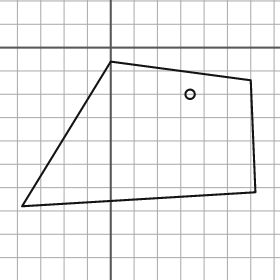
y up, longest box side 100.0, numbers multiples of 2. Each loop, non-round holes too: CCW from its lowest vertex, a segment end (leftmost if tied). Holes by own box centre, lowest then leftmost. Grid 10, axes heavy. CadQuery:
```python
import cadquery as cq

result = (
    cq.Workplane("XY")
    .moveTo(-38.0, -68.0)
    .lineTo(62.0, -62.0)
    .lineTo(60.0, -14.0)
    .lineTo(0.0, -6.0)
    .close()
    .moveTo(34.0, -20.0)
    .circle(2.0)
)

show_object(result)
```